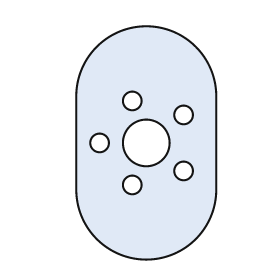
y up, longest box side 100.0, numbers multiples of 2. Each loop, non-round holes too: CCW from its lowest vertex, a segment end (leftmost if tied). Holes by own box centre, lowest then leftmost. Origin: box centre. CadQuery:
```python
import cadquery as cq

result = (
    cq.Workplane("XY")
    .moveTo(-30.0, -20.0)
    .threePointArc((0.0, -50.0), (30.0, -20.0))
    .lineTo(30.0, 20.0)
    .threePointArc((0.0, 50.0), (-30.0, 20.0))
    .close()
    .moveTo(-6.0, -18.0)
    .circle(4.0)
    .moveTo(16.0, -12.0)
    .circle(4.0)
    .moveTo(-20.0, 0.0)
    .circle(4.0)
    .moveTo(0.0, 0.0)
    .circle(10.0)
    .moveTo(16.0, 12.0)
    .circle(4.0)
    .moveTo(-6.0, 18.0)
    .circle(4.0)
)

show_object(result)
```